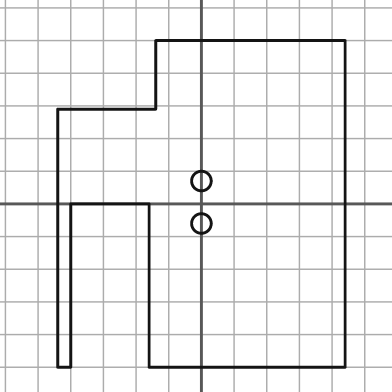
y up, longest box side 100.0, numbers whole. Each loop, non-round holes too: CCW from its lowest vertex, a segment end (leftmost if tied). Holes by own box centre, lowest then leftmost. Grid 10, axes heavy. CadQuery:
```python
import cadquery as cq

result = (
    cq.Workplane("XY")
    .moveTo(-44.0, -50.0)
    .lineTo(-40.0, -50.0)
    .lineTo(-40.0, 0.0)
    .lineTo(-16.0, 0.0)
    .lineTo(-16.0, -50.0)
    .lineTo(44.0, -50.0)
    .lineTo(44.0, 50.0)
    .lineTo(-14.0, 50.0)
    .lineTo(-14.0, 29.0)
    .lineTo(-44.0, 29.0)
    .close()
    .moveTo(0.0, -6.0)
    .circle(3.0)
    .moveTo(0.0, 7.0)
    .circle(3.0)
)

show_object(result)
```